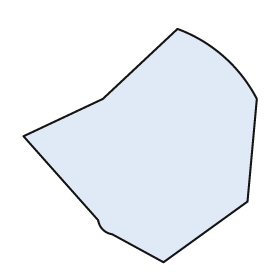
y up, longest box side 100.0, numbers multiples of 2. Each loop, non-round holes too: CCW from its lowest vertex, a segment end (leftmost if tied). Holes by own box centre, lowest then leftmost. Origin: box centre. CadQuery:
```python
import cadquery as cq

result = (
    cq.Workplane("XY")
    .moveTo(10.0, -50.0)
    .lineTo(46.0, -24.0)
    .lineTo(50.0, 20.0)
    .threePointArc((36.0, 38.0), (16.0, 50.0))
    .lineTo(-16.0, 20.0)
    .lineTo(-50.0, 4.0)
    .lineTo(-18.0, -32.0)
    .threePointArc((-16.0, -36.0), (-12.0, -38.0))
    .close()
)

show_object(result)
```